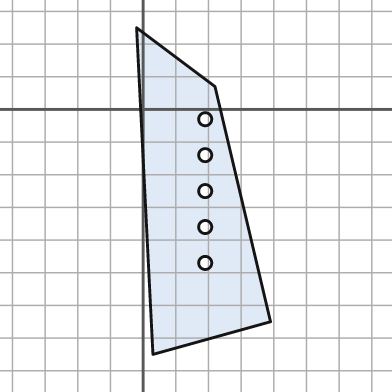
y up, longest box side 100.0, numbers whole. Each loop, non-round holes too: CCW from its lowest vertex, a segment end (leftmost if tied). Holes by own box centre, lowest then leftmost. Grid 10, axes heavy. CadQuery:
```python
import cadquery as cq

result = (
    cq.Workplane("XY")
    .moveTo(3.0, -75.0)
    .lineTo(39.0, -65.0)
    .lineTo(22.0, 7.0)
    .lineTo(-2.0, 25.0)
    .close()
    .moveTo(19.0, -47.0)
    .circle(2.0)
    .moveTo(19.0, -36.0)
    .circle(2.0)
    .moveTo(19.0, -25.0)
    .circle(2.0)
    .moveTo(19.0, -14.0)
    .circle(2.0)
    .moveTo(19.0, -3.0)
    .circle(2.0)
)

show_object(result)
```